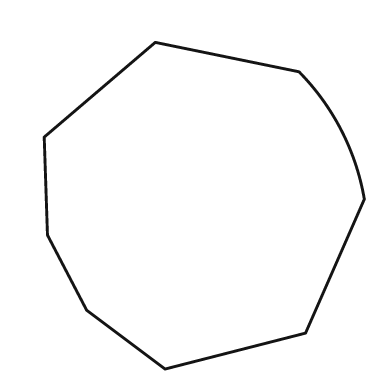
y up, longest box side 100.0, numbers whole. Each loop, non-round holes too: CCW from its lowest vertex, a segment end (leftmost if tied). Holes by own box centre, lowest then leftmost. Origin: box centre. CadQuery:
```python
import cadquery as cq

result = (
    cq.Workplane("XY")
    .moveTo(-12.0, -50.0)
    .lineTo(31.0, -39.0)
    .lineTo(49.0, 2.0)
    .threePointArc((42.0, 23.0), (29.0, 41.0))
    .lineTo(-15.0, 50.0)
    .lineTo(-49.0, 21.0)
    .lineTo(-48.0, -9.0)
    .lineTo(-36.0, -32.0)
    .close()
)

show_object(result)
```